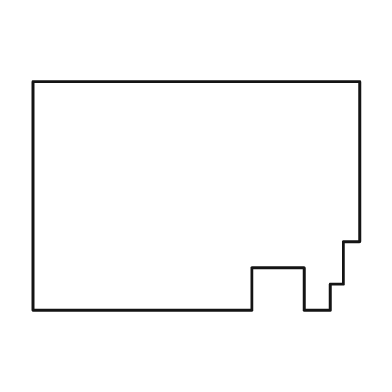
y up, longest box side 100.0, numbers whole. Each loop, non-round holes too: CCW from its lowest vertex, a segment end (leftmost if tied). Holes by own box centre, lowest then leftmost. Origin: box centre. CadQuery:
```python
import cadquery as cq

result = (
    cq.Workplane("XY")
    .moveTo(-50.0, -35.0)
    .lineTo(17.0, -35.0)
    .lineTo(17.0, -22.0)
    .lineTo(33.0, -22.0)
    .lineTo(33.0, -35.0)
    .lineTo(41.0, -35.0)
    .lineTo(41.0, -27.0)
    .lineTo(45.0, -27.0)
    .lineTo(45.0, -14.0)
    .lineTo(50.0, -14.0)
    .lineTo(50.0, 35.0)
    .lineTo(-50.0, 35.0)
    .close()
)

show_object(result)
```